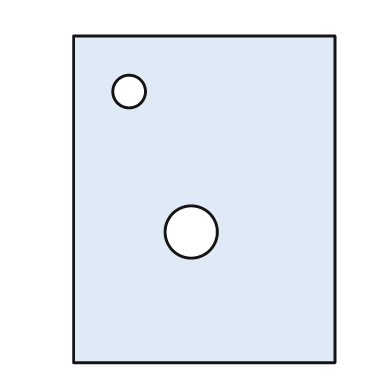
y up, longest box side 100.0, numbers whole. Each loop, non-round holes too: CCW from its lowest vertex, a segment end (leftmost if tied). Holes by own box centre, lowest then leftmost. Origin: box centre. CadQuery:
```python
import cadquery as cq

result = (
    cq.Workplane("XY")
    .moveTo(-40.0, -50.0)
    .lineTo(40.0, -50.0)
    .lineTo(40.0, 50.0)
    .lineTo(-40.0, 50.0)
    .close()
    .moveTo(-4.0, -10.0)
    .circle(8.0)
    .moveTo(-23.0, 33.0)
    .circle(5.0)
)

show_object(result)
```